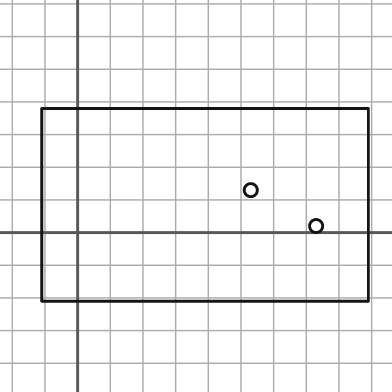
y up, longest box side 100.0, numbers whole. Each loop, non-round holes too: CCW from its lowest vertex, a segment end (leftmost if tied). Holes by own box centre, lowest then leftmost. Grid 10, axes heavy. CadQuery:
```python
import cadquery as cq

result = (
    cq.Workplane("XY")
    .moveTo(-11.0, -21.0)
    .lineTo(89.0, -21.0)
    .lineTo(89.0, 38.0)
    .lineTo(-11.0, 38.0)
    .close()
    .moveTo(73.0, 2.0)
    .circle(2.0)
    .moveTo(53.0, 13.0)
    .circle(2.0)
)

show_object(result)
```